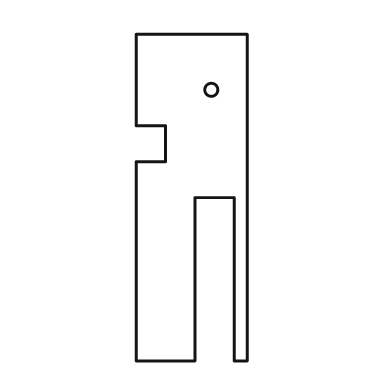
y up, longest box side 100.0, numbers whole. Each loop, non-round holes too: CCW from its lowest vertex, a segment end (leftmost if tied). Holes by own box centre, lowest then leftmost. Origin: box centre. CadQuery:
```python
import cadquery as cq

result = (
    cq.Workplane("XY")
    .moveTo(-17.0, -50.0)
    .lineTo(1.0, -50.0)
    .lineTo(1.0, 0.0)
    .lineTo(13.0, 0.0)
    .lineTo(13.0, -50.0)
    .lineTo(17.0, -50.0)
    .lineTo(17.0, 50.0)
    .lineTo(-17.0, 50.0)
    .lineTo(-17.0, 22.0)
    .lineTo(-8.0, 22.0)
    .lineTo(-8.0, 11.0)
    .lineTo(-17.0, 11.0)
    .close()
    .moveTo(6.0, 33.0)
    .circle(2.0)
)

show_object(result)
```